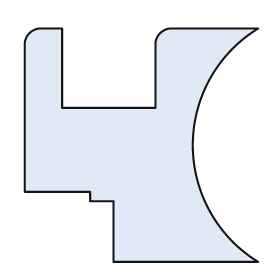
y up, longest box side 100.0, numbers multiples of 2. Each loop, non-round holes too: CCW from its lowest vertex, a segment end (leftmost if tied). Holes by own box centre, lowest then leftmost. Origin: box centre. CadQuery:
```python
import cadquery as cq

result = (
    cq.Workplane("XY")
    .moveTo(-12.0, -50.0)
    .lineTo(50.0, -50.0)
    .threePointArc((22.0, 0.0), (50.0, 50.0))
    .lineTo(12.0, 50.0)
    .threePointArc((8.0, 48.0), (6.0, 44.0))
    .lineTo(6.0, 16.0)
    .lineTo(-34.0, 16.0)
    .lineTo(-34.0, 50.0)
    .lineTo(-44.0, 50.0)
    .threePointArc((-48.0, 48.0), (-50.0, 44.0))
    .lineTo(-50.0, -20.0)
    .lineTo(-22.0, -20.0)
    .lineTo(-22.0, -24.0)
    .lineTo(-12.0, -24.0)
    .close()
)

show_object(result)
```